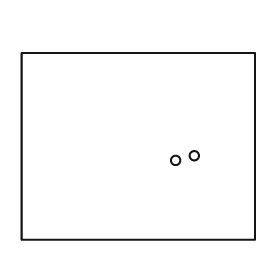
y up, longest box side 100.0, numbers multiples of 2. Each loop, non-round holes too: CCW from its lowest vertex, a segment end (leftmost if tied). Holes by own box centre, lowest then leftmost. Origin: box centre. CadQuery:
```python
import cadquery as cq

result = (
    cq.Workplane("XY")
    .moveTo(-50.0, -40.0)
    .lineTo(50.0, -40.0)
    .lineTo(50.0, 40.0)
    .lineTo(-50.0, 40.0)
    .close()
    .moveTo(16.0, -6.0)
    .circle(2.0)
    .moveTo(24.0, -4.0)
    .circle(2.0)
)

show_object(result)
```